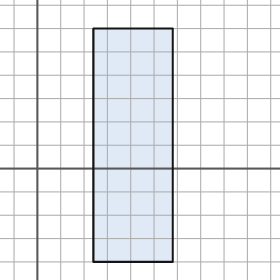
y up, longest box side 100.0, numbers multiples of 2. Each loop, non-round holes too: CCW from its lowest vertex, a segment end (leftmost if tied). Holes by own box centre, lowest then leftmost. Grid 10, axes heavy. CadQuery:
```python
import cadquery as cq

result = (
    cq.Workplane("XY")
    .moveTo(24.0, -40.0)
    .lineTo(58.0, -40.0)
    .lineTo(58.0, 60.0)
    .lineTo(24.0, 60.0)
    .close()
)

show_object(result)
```